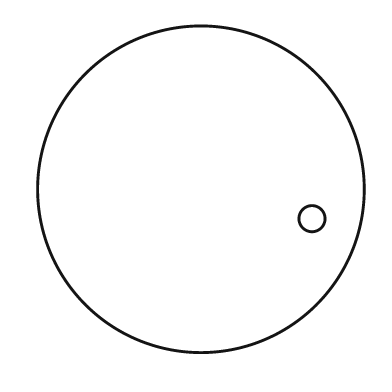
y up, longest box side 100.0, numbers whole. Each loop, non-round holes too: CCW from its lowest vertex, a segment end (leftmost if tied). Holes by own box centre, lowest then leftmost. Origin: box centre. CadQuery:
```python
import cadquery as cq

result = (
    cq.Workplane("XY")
    .moveTo(0.0, 0.0)
    .circle(50.0)
    .moveTo(34.0, -9.0)
    .circle(4.0)
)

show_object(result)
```